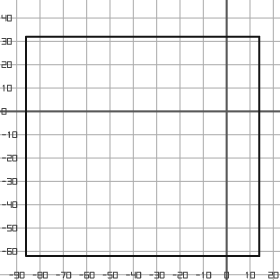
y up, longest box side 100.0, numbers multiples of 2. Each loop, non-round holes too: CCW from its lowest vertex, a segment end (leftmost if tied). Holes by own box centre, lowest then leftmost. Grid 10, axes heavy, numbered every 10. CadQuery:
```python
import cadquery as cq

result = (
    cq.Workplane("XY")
    .moveTo(-86.0, -62.0)
    .lineTo(14.0, -62.0)
    .lineTo(14.0, 32.0)
    .lineTo(-86.0, 32.0)
    .close()
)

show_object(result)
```